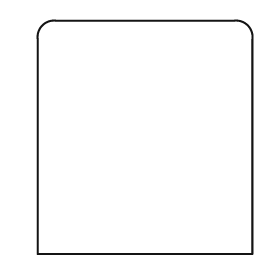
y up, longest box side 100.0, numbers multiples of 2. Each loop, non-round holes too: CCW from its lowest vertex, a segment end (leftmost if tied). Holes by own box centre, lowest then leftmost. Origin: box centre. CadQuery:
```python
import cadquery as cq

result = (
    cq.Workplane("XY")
    .moveTo(-46.0, -50.0)
    .lineTo(46.0, -50.0)
    .lineTo(46.0, 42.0)
    .threePointArc((44.0, 48.0), (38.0, 50.0))
    .lineTo(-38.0, 50.0)
    .threePointArc((-44.0, 48.0), (-46.0, 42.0))
    .close()
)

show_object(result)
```